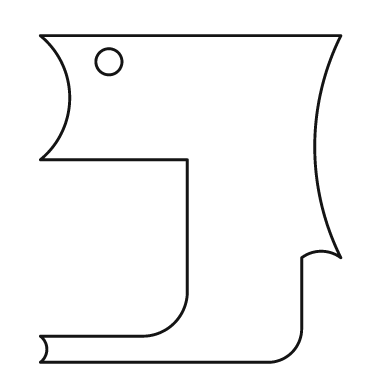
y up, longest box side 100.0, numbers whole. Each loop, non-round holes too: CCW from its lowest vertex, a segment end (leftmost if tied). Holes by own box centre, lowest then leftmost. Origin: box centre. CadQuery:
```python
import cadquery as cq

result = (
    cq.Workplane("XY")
    .moveTo(-46.0, -50.0)
    .lineTo(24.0, -50.0)
    .threePointArc((31.0, -47.0), (34.0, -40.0))
    .lineTo(34.0, -18.0)
    .threePointArc((40.0, -16.0), (46.0, -18.0))
    .threePointArc((38.0, 16.0), (46.0, 50.0))
    .lineTo(-46.0, 50.0)
    .threePointArc((-37.0, 31.0), (-46.0, 12.0))
    .lineTo(-1.0, 12.0)
    .lineTo(-1.0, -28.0)
    .threePointArc((-5.0, -38.0), (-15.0, -42.0))
    .lineTo(-46.0, -42.0)
    .threePointArc((-44.0, -46.0), (-46.0, -50.0))
    .close()
    .moveTo(-25.0, 42.0)
    .circle(4.0)
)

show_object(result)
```